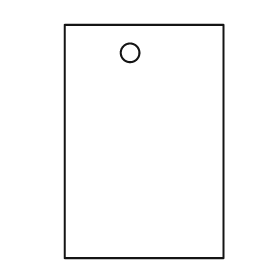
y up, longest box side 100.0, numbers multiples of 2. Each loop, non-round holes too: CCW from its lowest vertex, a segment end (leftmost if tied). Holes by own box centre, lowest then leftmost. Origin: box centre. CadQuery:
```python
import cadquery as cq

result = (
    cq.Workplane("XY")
    .moveTo(-34.0, -50.0)
    .lineTo(34.0, -50.0)
    .lineTo(34.0, 50.0)
    .lineTo(-34.0, 50.0)
    .close()
    .moveTo(-6.0, 38.0)
    .circle(4.0)
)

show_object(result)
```